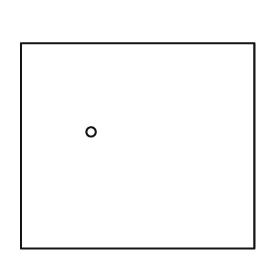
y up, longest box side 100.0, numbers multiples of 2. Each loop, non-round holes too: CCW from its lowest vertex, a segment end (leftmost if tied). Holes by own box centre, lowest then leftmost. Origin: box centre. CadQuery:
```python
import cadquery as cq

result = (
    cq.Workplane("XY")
    .moveTo(-50.0, -44.0)
    .lineTo(50.0, -44.0)
    .lineTo(50.0, 44.0)
    .lineTo(-50.0, 44.0)
    .close()
    .moveTo(-20.0, 6.0)
    .circle(2.0)
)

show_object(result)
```